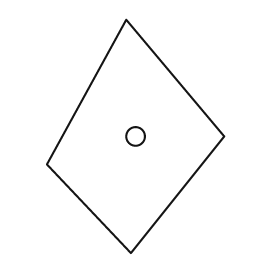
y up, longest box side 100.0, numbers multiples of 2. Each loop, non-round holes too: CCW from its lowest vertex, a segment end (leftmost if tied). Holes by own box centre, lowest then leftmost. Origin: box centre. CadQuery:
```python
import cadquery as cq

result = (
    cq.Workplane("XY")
    .moveTo(-2.0, -50.0)
    .lineTo(38.0, 0.0)
    .lineTo(-4.0, 50.0)
    .lineTo(-38.0, -12.0)
    .close()
    .moveTo(0.0, 0.0)
    .circle(4.0)
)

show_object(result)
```